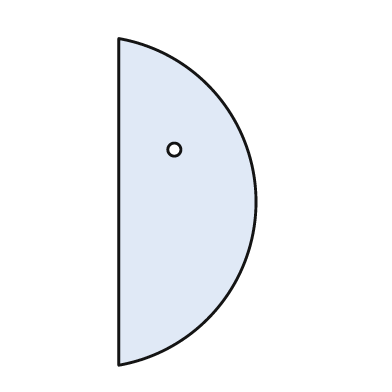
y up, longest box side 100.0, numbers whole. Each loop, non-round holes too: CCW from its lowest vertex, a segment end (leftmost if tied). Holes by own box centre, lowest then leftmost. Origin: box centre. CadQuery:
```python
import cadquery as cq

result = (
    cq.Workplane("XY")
    .moveTo(-21.0, -50.0)
    .threePointArc((21.0, 0.0), (-21.0, 50.0))
    .close()
    .moveTo(-4.0, 16.0)
    .circle(2.0)
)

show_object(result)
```